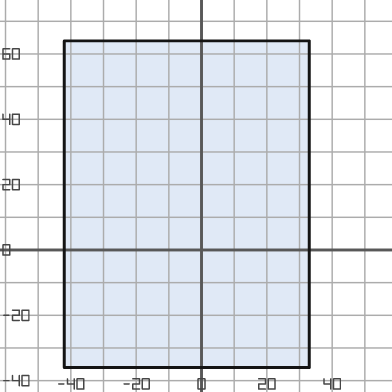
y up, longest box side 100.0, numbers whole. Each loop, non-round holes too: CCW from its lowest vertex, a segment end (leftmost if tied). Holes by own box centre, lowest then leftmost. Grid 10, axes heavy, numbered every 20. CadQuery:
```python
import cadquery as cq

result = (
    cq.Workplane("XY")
    .moveTo(-42.0, -36.0)
    .lineTo(33.0, -36.0)
    .lineTo(33.0, 64.0)
    .lineTo(-42.0, 64.0)
    .close()
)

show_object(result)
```